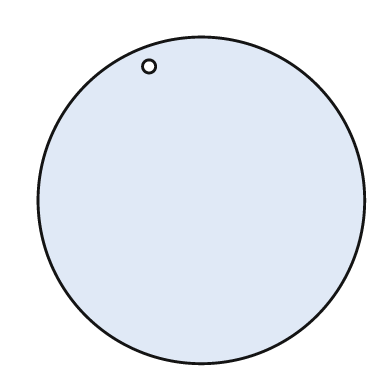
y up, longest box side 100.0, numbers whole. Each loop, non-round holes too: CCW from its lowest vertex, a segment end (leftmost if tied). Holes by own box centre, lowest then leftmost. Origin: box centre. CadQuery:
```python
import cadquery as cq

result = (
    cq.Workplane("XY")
    .moveTo(0.0, 0.0)
    .circle(50.0)
    .moveTo(-16.0, 41.0)
    .circle(2.0)
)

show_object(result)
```